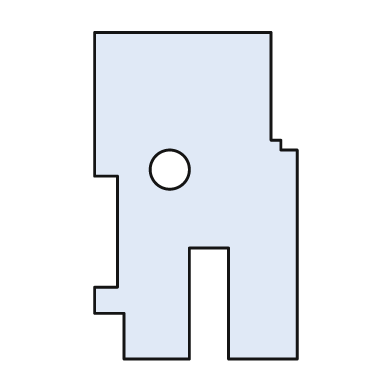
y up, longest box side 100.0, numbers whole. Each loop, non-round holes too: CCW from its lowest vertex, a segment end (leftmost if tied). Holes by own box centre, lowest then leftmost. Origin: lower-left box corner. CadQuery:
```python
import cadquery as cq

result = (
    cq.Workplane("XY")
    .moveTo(9.0, 0.0)
    .lineTo(29.0, 0.0)
    .lineTo(29.0, 34.0)
    .lineTo(41.0, 34.0)
    .lineTo(41.0, 0.0)
    .lineTo(62.0, 0.0)
    .lineTo(62.0, 64.0)
    .lineTo(57.0, 64.0)
    .lineTo(57.0, 67.0)
    .lineTo(54.0, 67.0)
    .lineTo(54.0, 100.0)
    .lineTo(0.0, 100.0)
    .lineTo(0.0, 56.0)
    .lineTo(7.0, 56.0)
    .lineTo(7.0, 22.0)
    .lineTo(0.0, 22.0)
    .lineTo(0.0, 14.0)
    .lineTo(9.0, 14.0)
    .close()
    .moveTo(23.0, 58.0)
    .circle(6.0)
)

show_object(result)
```